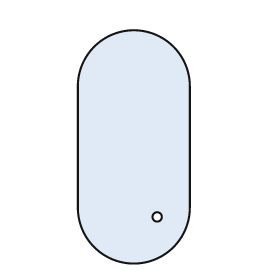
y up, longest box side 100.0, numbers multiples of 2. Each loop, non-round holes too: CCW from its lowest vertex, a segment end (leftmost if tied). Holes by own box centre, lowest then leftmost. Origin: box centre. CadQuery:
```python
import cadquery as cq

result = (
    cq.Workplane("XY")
    .moveTo(-24.0, -26.0)
    .threePointArc((0.0, -50.0), (24.0, -26.0))
    .lineTo(24.0, 26.0)
    .threePointArc((0.0, 50.0), (-24.0, 26.0))
    .close()
    .moveTo(10.0, -30.0)
    .circle(2.0)
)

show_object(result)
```